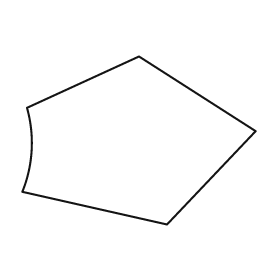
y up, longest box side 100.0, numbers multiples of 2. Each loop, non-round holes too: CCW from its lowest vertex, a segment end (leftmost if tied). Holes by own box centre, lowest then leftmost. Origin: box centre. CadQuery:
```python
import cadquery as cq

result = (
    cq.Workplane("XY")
    .moveTo(12.0, -36.0)
    .lineTo(50.0, 4.0)
    .lineTo(0.0, 36.0)
    .lineTo(-48.0, 14.0)
    .threePointArc((-46.0, -4.0), (-50.0, -22.0))
    .close()
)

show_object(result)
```